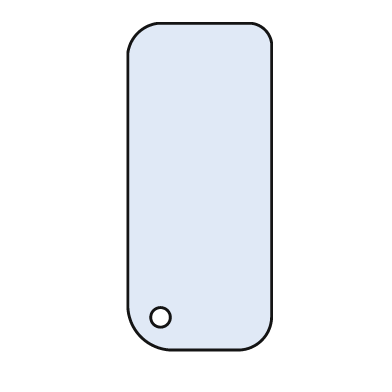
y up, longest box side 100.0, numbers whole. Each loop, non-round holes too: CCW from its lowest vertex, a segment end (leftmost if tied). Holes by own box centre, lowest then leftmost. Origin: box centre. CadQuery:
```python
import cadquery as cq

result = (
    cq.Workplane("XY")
    .moveTo(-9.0, -50.0)
    .lineTo(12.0, -50.0)
    .threePointArc((19.0, -47.0), (22.0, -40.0))
    .lineTo(22.0, 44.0)
    .threePointArc((20.0, 48.0), (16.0, 50.0))
    .lineTo(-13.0, 50.0)
    .threePointArc((-19.0, 47.0), (-22.0, 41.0))
    .lineTo(-22.0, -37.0)
    .threePointArc((-18.0, -46.0), (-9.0, -50.0))
    .close()
    .moveTo(-12.0, -40.0)
    .circle(3.0)
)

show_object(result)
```